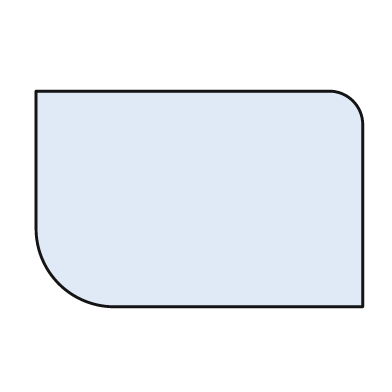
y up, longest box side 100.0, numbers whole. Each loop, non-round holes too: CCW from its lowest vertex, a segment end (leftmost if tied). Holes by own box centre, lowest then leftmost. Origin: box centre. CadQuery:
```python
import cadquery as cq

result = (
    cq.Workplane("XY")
    .moveTo(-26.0, -33.0)
    .lineTo(50.0, -33.0)
    .lineTo(50.0, 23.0)
    .threePointArc((47.0, 30.0), (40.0, 33.0))
    .lineTo(-50.0, 33.0)
    .lineTo(-50.0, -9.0)
    .threePointArc((-43.0, -26.0), (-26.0, -33.0))
    .close()
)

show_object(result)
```